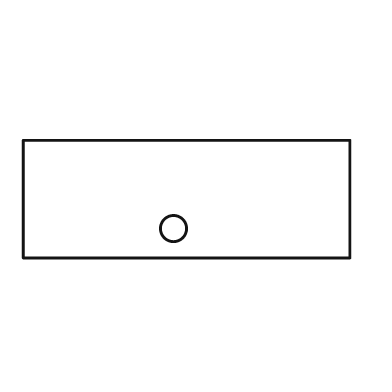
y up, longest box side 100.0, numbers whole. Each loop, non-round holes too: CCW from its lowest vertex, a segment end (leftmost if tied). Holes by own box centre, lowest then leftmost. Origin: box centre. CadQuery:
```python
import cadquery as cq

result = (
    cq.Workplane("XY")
    .moveTo(-50.0, -18.0)
    .lineTo(50.0, -18.0)
    .lineTo(50.0, 18.0)
    .lineTo(-50.0, 18.0)
    .close()
    .moveTo(-4.0, -9.0)
    .circle(4.0)
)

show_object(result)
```